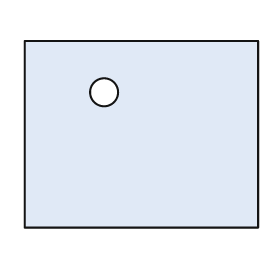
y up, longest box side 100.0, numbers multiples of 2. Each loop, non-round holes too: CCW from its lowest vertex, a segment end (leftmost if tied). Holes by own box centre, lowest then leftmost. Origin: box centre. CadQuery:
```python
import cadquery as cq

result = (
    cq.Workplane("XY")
    .moveTo(-50.0, -40.0)
    .lineTo(50.0, -40.0)
    .lineTo(50.0, 40.0)
    .lineTo(-50.0, 40.0)
    .close()
    .moveTo(-16.0, 18.0)
    .circle(6.0)
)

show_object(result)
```